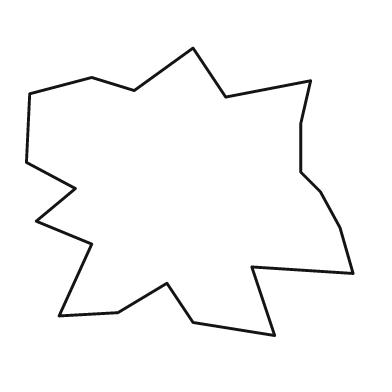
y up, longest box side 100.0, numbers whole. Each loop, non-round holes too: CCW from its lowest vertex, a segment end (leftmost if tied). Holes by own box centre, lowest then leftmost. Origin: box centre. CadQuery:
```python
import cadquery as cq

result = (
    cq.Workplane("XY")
    .moveTo(26.0, -44.0)
    .lineTo(19.0, -23.0)
    .lineTo(50.0, -25.0)
    .lineTo(46.0, -11.0)
    .lineTo(40.0, 0.0)
    .lineTo(34.0, 6.0)
    .lineTo(34.0, 21.0)
    .lineTo(37.0, 34.0)
    .lineTo(11.0, 29.0)
    .lineTo(1.0, 44.0)
    .lineTo(-17.0, 31.0)
    .lineTo(-30.0, 35.0)
    .lineTo(-49.0, 30.0)
    .lineTo(-50.0, 9.0)
    .lineTo(-35.0, 1.0)
    .lineTo(-47.0, -9.0)
    .lineTo(-30.0, -16.0)
    .lineTo(-40.0, -38.0)
    .lineTo(-22.0, -37.0)
    .lineTo(-7.0, -28.0)
    .lineTo(1.0, -40.0)
    .close()
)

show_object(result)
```